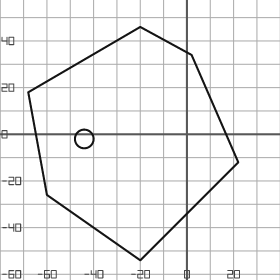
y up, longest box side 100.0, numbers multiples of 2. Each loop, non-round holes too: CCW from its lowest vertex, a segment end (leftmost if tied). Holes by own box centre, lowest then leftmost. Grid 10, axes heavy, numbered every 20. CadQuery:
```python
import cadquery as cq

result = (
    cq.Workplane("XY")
    .moveTo(-20.0, -54.0)
    .lineTo(22.0, -12.0)
    .lineTo(2.0, 34.0)
    .lineTo(-20.0, 46.0)
    .lineTo(-68.0, 18.0)
    .lineTo(-60.0, -26.0)
    .close()
    .moveTo(-44.0, -2.0)
    .circle(4.0)
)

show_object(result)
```